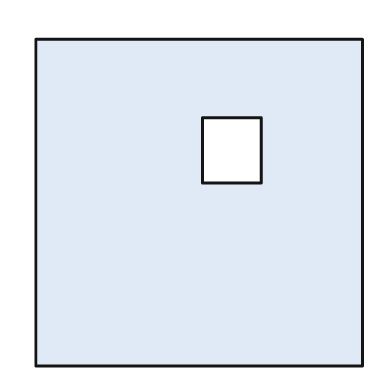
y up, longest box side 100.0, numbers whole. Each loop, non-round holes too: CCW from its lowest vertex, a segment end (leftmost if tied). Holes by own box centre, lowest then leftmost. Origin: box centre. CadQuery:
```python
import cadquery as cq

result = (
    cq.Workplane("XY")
    .moveTo(-50.0, -50.0)
    .lineTo(50.0, -50.0)
    .lineTo(50.0, 50.0)
    .lineTo(-50.0, 50.0)
    .close()
    .moveTo(1.0, 6.0)
    .lineTo(19.0, 6.0)
    .lineTo(19.0, 26.0)
    .lineTo(1.0, 26.0)
    .close()
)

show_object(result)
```